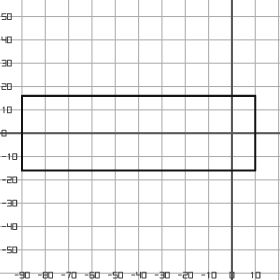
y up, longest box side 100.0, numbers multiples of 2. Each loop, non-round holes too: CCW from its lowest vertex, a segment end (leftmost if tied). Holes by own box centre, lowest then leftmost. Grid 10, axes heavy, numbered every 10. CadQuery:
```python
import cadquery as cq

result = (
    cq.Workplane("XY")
    .moveTo(-90.0, -16.0)
    .lineTo(10.0, -16.0)
    .lineTo(10.0, 16.0)
    .lineTo(-90.0, 16.0)
    .close()
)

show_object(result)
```